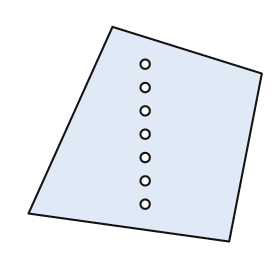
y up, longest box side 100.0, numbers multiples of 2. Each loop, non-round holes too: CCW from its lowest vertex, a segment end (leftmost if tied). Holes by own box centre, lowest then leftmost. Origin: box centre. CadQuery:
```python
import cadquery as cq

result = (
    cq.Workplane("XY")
    .moveTo(36.0, -46.0)
    .lineTo(50.0, 26.0)
    .lineTo(-14.0, 46.0)
    .lineTo(-50.0, -34.0)
    .close()
    .moveTo(0.0, -30.0)
    .circle(2.0)
    .moveTo(0.0, -20.0)
    .circle(2.0)
    .moveTo(0.0, -10.0)
    .circle(2.0)
    .moveTo(0.0, 0.0)
    .circle(2.0)
    .moveTo(0.0, 10.0)
    .circle(2.0)
    .moveTo(0.0, 20.0)
    .circle(2.0)
    .moveTo(0.0, 30.0)
    .circle(2.0)
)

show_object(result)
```